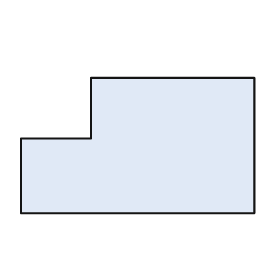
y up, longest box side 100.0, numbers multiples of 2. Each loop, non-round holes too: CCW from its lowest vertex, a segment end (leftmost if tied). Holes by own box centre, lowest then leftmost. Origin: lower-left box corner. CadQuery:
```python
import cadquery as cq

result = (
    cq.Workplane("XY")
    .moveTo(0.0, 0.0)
    .lineTo(100.0, 0.0)
    .lineTo(100.0, 58.0)
    .lineTo(30.0, 58.0)
    .lineTo(30.0, 32.0)
    .lineTo(0.0, 32.0)
    .close()
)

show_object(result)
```